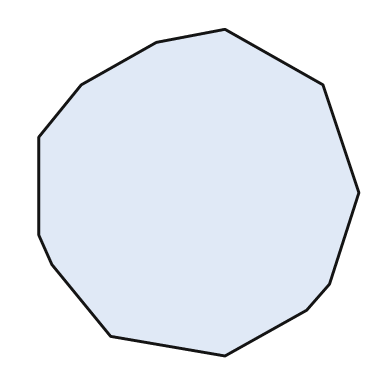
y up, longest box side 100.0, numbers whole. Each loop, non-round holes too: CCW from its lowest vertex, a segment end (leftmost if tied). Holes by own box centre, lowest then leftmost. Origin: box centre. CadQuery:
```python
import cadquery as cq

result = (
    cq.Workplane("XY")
    .moveTo(8.0, -50.0)
    .lineTo(33.0, -36.0)
    .lineTo(40.0, -28.0)
    .lineTo(49.0, 0.0)
    .lineTo(38.0, 33.0)
    .lineTo(8.0, 50.0)
    .lineTo(-13.0, 46.0)
    .lineTo(-36.0, 33.0)
    .lineTo(-49.0, 17.0)
    .lineTo(-49.0, -13.0)
    .lineTo(-45.0, -22.0)
    .lineTo(-27.0, -44.0)
    .close()
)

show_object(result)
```